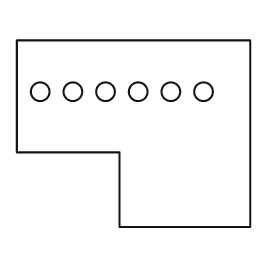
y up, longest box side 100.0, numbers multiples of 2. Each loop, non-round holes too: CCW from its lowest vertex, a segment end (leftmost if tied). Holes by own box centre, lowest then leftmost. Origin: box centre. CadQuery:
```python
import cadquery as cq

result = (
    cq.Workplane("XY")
    .moveTo(-6.0, -40.0)
    .lineTo(50.0, -40.0)
    .lineTo(50.0, 40.0)
    .lineTo(-50.0, 40.0)
    .lineTo(-50.0, -8.0)
    .lineTo(-6.0, -8.0)
    .close()
    .moveTo(-40.0, 18.0)
    .circle(4.0)
    .moveTo(-26.0, 18.0)
    .circle(4.0)
    .moveTo(-12.0, 18.0)
    .circle(4.0)
    .moveTo(2.0, 18.0)
    .circle(4.0)
    .moveTo(16.0, 18.0)
    .circle(4.0)
    .moveTo(30.0, 18.0)
    .circle(4.0)
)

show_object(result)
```